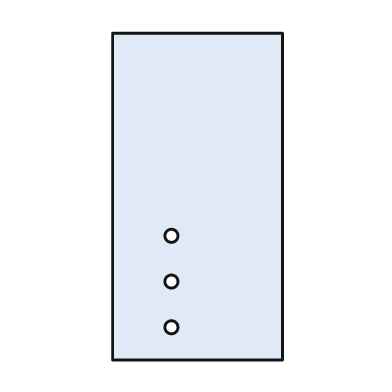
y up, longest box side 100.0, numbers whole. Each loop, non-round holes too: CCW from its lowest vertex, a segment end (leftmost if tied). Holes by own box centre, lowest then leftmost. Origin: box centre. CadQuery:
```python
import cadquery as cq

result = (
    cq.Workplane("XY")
    .moveTo(-26.0, -50.0)
    .lineTo(26.0, -50.0)
    .lineTo(26.0, 50.0)
    .lineTo(-26.0, 50.0)
    .close()
    .moveTo(-8.0, -40.0)
    .circle(2.0)
    .moveTo(-8.0, -26.0)
    .circle(2.0)
    .moveTo(-8.0, -12.0)
    .circle(2.0)
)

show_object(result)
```